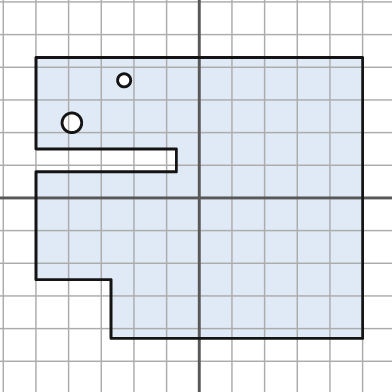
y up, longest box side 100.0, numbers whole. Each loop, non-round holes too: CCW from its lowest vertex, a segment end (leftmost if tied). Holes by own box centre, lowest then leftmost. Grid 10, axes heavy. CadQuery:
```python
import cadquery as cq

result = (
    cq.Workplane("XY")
    .moveTo(-27.0, -43.0)
    .lineTo(50.0, -43.0)
    .lineTo(50.0, 43.0)
    .lineTo(-50.0, 43.0)
    .lineTo(-50.0, 15.0)
    .lineTo(-7.0, 15.0)
    .lineTo(-7.0, 8.0)
    .lineTo(-50.0, 8.0)
    .lineTo(-50.0, -25.0)
    .lineTo(-27.0, -25.0)
    .close()
    .moveTo(-39.0, 23.0)
    .circle(3.0)
    .moveTo(-23.0, 36.0)
    .circle(2.0)
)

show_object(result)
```